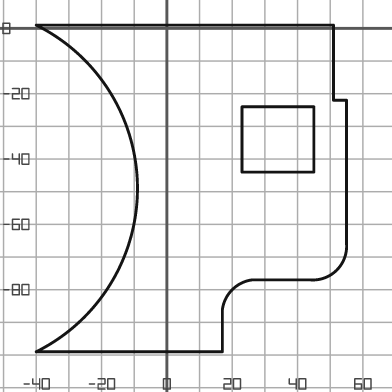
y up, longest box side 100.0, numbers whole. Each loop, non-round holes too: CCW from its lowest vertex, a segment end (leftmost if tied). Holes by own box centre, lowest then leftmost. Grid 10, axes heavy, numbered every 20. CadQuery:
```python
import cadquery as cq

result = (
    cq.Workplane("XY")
    .moveTo(-40.0, -99.0)
    .lineTo(17.0, -99.0)
    .lineTo(17.0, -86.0)
    .threePointArc((20.0, -80.0), (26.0, -77.0))
    .lineTo(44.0, -77.0)
    .threePointArc((52.0, -74.0), (55.0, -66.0))
    .lineTo(55.0, -22.0)
    .lineTo(51.0, -22.0)
    .lineTo(51.0, 1.0)
    .lineTo(-40.0, 1.0)
    .threePointArc((-9.0, -49.0), (-40.0, -99.0))
    .close()
    .moveTo(23.0, -44.0)
    .lineTo(45.0, -44.0)
    .lineTo(45.0, -24.0)
    .lineTo(23.0, -24.0)
    .close()
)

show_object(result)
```